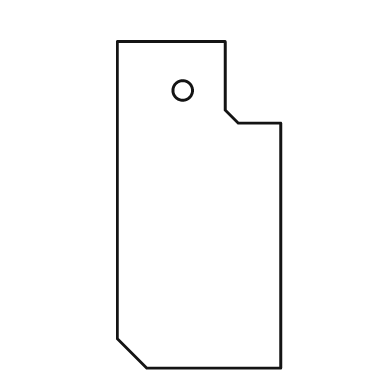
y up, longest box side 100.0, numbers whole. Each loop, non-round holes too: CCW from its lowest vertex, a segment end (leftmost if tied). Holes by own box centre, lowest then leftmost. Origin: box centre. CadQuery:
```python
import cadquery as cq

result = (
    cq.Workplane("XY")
    .moveTo(-16.0, -50.0)
    .lineTo(25.0, -50.0)
    .lineTo(25.0, 25.0)
    .lineTo(12.0, 25.0)
    .lineTo(8.0, 29.0)
    .lineTo(8.0, 50.0)
    .lineTo(-25.0, 50.0)
    .lineTo(-25.0, -41.0)
    .close()
    .moveTo(-5.0, 35.0)
    .circle(3.0)
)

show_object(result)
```